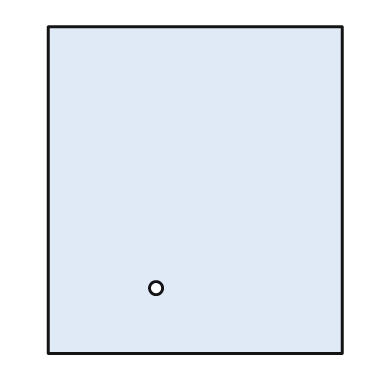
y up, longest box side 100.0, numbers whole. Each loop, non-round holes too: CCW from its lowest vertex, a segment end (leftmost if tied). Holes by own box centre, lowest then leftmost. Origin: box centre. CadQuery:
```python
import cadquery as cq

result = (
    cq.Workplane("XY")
    .moveTo(-45.0, -50.0)
    .lineTo(45.0, -50.0)
    .lineTo(45.0, 50.0)
    .lineTo(-45.0, 50.0)
    .close()
    .moveTo(-12.0, -30.0)
    .circle(2.0)
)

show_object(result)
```